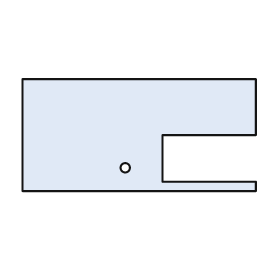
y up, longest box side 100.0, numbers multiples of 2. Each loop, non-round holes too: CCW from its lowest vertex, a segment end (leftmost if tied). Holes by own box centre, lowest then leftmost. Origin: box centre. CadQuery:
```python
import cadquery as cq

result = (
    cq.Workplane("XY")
    .moveTo(-50.0, -24.0)
    .lineTo(50.0, -24.0)
    .lineTo(50.0, -20.0)
    .lineTo(10.0, -20.0)
    .lineTo(10.0, 0.0)
    .lineTo(50.0, 0.0)
    .lineTo(50.0, 24.0)
    .lineTo(-50.0, 24.0)
    .close()
    .moveTo(-6.0, -14.0)
    .circle(2.0)
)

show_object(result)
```